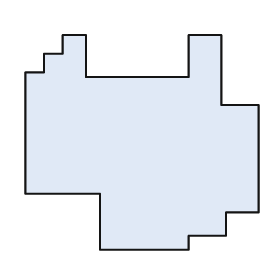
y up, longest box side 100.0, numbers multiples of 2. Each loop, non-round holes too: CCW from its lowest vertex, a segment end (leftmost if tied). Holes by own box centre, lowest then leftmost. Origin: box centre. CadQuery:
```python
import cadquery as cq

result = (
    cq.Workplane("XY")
    .moveTo(-18.0, -46.0)
    .lineTo(20.0, -46.0)
    .lineTo(20.0, -40.0)
    .lineTo(36.0, -40.0)
    .lineTo(36.0, -30.0)
    .lineTo(50.0, -30.0)
    .lineTo(50.0, 16.0)
    .lineTo(34.0, 16.0)
    .lineTo(34.0, 46.0)
    .lineTo(20.0, 46.0)
    .lineTo(20.0, 28.0)
    .lineTo(-24.0, 28.0)
    .lineTo(-24.0, 46.0)
    .lineTo(-34.0, 46.0)
    .lineTo(-34.0, 38.0)
    .lineTo(-42.0, 38.0)
    .lineTo(-42.0, 30.0)
    .lineTo(-50.0, 30.0)
    .lineTo(-50.0, -22.0)
    .lineTo(-18.0, -22.0)
    .close()
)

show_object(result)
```